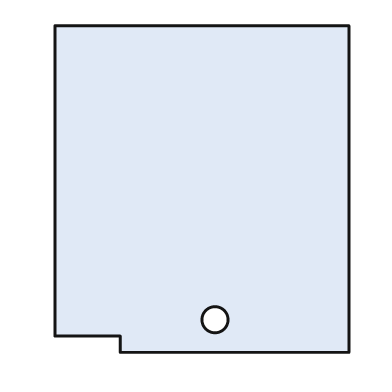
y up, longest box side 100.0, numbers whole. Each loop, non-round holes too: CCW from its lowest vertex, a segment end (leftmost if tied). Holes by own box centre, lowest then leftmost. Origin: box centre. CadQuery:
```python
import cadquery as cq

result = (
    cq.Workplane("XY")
    .moveTo(-25.0, -50.0)
    .lineTo(45.0, -50.0)
    .lineTo(45.0, 50.0)
    .lineTo(-45.0, 50.0)
    .lineTo(-45.0, -45.0)
    .lineTo(-25.0, -45.0)
    .close()
    .moveTo(4.0, -40.0)
    .circle(4.0)
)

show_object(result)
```